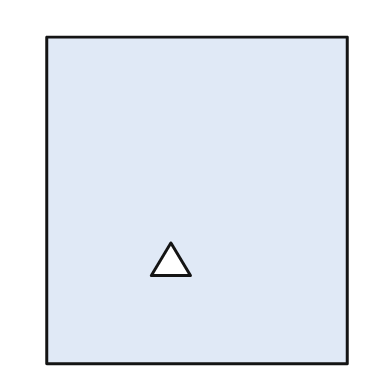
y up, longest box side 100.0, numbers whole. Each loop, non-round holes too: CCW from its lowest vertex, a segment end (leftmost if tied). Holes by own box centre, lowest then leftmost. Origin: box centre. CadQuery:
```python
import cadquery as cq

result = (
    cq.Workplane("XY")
    .moveTo(-46.0, -50.0)
    .lineTo(46.0, -50.0)
    .lineTo(46.0, 50.0)
    .lineTo(-46.0, 50.0)
    .close()
    .moveTo(-14.0, -23.0)
    .lineTo(-2.0, -23.0)
    .lineTo(-8.0, -13.0)
    .close()
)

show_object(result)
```